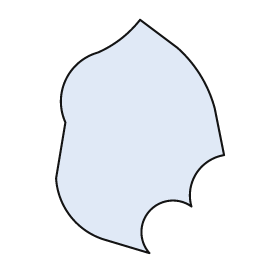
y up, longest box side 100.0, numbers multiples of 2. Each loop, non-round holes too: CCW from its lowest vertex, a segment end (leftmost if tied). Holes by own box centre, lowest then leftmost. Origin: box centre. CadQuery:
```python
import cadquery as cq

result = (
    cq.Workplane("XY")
    .moveTo(4.0, -50.0)
    .threePointArc((4.0, -32.0), (22.0, -30.0))
    .threePointArc((24.0, -16.0), (36.0, -8.0))
    .lineTo(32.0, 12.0)
    .threePointArc((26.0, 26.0), (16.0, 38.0))
    .lineTo(0.0, 50.0)
    .threePointArc((-8.0, 42.0), (-18.0, 36.0))
    .threePointArc((-32.0, 24.0), (-32.0, 6.0))
    .lineTo(-36.0, -18.0)
    .threePointArc((-30.0, -34.0), (-16.0, -44.0))
    .close()
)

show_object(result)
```